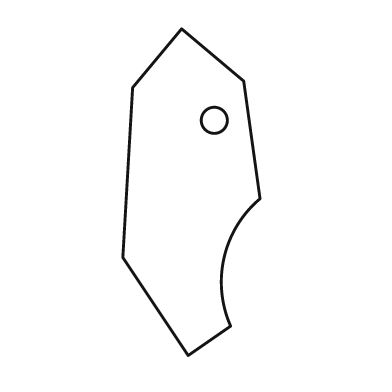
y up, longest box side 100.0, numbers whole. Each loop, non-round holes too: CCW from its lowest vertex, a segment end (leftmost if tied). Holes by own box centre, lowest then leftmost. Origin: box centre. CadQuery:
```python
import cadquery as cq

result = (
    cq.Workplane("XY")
    .moveTo(-1.0, -50.0)
    .lineTo(12.0, -41.0)
    .threePointArc((10.0, -20.0), (21.0, -2.0))
    .lineTo(16.0, 34.0)
    .lineTo(-3.0, 50.0)
    .lineTo(-18.0, 32.0)
    .lineTo(-21.0, -20.0)
    .close()
    .moveTo(7.0, 22.0)
    .circle(4.0)
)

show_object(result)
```